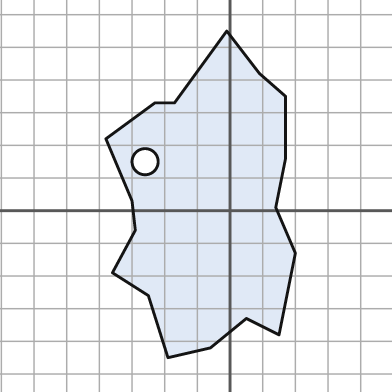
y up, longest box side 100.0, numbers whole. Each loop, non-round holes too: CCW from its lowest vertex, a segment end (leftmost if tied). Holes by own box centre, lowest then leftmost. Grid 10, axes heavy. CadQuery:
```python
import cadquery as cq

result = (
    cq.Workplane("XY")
    .moveTo(-19.0, -45.0)
    .lineTo(-6.0, -42.0)
    .lineTo(5.0, -33.0)
    .lineTo(15.0, -38.0)
    .lineTo(20.0, -13.0)
    .lineTo(14.0, 1.0)
    .lineTo(17.0, 16.0)
    .lineTo(17.0, 35.0)
    .lineTo(9.0, 42.0)
    .lineTo(-1.0, 55.0)
    .lineTo(-17.0, 33.0)
    .lineTo(-23.0, 33.0)
    .lineTo(-38.0, 22.0)
    .lineTo(-30.0, 3.0)
    .lineTo(-29.0, -6.0)
    .lineTo(-36.0, -19.0)
    .lineTo(-25.0, -26.0)
    .close()
    .moveTo(-26.0, 15.0)
    .circle(4.0)
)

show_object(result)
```